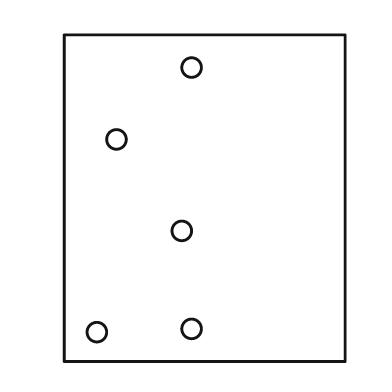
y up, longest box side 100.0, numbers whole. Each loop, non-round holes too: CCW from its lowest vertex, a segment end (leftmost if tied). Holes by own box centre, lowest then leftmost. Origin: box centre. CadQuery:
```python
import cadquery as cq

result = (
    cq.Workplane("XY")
    .moveTo(-43.0, -50.0)
    .lineTo(43.0, -50.0)
    .lineTo(43.0, 50.0)
    .lineTo(-43.0, 50.0)
    .close()
    .moveTo(-33.0, -41.0)
    .circle(3.0)
    .moveTo(-4.0, -40.0)
    .circle(3.0)
    .moveTo(-7.0, -10.0)
    .circle(3.0)
    .moveTo(-27.0, 18.0)
    .circle(3.0)
    .moveTo(-4.0, 40.0)
    .circle(3.0)
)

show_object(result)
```